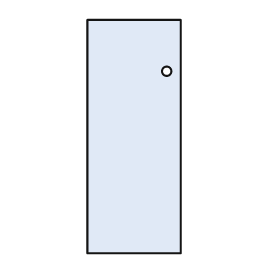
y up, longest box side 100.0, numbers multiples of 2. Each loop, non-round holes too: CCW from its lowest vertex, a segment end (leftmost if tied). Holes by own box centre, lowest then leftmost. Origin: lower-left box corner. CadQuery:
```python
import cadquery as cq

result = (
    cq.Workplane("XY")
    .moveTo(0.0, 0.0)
    .lineTo(40.0, 0.0)
    .lineTo(40.0, 100.0)
    .lineTo(0.0, 100.0)
    .close()
    .moveTo(34.0, 78.0)
    .circle(2.0)
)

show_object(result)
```